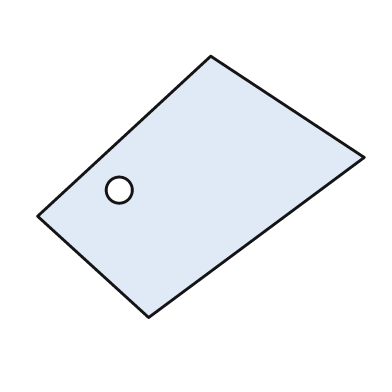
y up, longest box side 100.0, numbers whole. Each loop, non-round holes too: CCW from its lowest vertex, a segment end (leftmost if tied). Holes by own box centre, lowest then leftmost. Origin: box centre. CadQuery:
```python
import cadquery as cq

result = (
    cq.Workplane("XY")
    .moveTo(-16.0, -40.0)
    .lineTo(50.0, 9.0)
    .lineTo(3.0, 40.0)
    .lineTo(-50.0, -9.0)
    .close()
    .moveTo(-25.0, -1.0)
    .circle(4.0)
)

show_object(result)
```